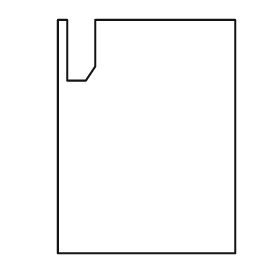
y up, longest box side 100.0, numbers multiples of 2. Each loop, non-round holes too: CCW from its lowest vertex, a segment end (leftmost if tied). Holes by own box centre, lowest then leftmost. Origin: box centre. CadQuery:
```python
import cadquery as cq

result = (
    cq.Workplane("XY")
    .moveTo(-38.0, -50.0)
    .lineTo(38.0, -50.0)
    .lineTo(38.0, 50.0)
    .lineTo(-22.0, 50.0)
    .lineTo(-22.0, 30.0)
    .lineTo(-26.0, 24.0)
    .lineTo(-34.0, 24.0)
    .lineTo(-34.0, 50.0)
    .lineTo(-38.0, 50.0)
    .close()
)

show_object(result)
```